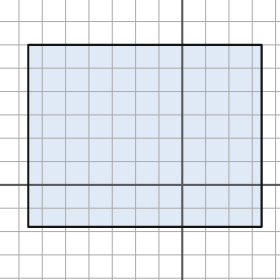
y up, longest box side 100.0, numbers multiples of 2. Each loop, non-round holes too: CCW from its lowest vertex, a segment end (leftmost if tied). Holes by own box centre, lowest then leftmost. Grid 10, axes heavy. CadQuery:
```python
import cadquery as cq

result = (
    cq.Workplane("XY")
    .moveTo(-66.0, -18.0)
    .lineTo(34.0, -18.0)
    .lineTo(34.0, 60.0)
    .lineTo(-66.0, 60.0)
    .close()
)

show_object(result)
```